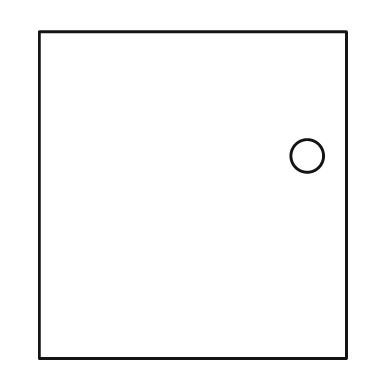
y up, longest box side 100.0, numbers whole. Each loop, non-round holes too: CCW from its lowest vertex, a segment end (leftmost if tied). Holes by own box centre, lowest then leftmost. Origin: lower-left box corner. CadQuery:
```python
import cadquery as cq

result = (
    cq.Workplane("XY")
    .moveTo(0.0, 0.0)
    .lineTo(94.0, 0.0)
    .lineTo(94.0, 100.0)
    .lineTo(0.0, 100.0)
    .close()
    .moveTo(82.0, 62.0)
    .circle(5.0)
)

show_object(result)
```